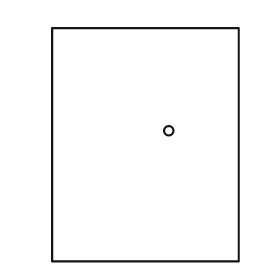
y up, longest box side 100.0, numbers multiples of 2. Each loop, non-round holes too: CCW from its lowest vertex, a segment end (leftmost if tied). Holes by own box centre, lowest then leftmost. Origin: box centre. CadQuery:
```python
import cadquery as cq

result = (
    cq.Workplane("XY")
    .moveTo(-40.0, -50.0)
    .lineTo(40.0, -50.0)
    .lineTo(40.0, 50.0)
    .lineTo(-40.0, 50.0)
    .close()
    .moveTo(10.0, 6.0)
    .circle(2.0)
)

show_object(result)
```